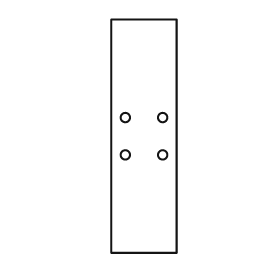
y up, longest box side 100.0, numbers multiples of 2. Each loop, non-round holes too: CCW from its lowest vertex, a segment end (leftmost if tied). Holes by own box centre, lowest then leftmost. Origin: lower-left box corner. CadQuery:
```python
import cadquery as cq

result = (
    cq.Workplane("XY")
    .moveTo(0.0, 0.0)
    .lineTo(28.0, 0.0)
    .lineTo(28.0, 100.0)
    .lineTo(0.0, 100.0)
    .close()
    .moveTo(6.0, 42.0)
    .circle(2.0)
    .moveTo(22.0, 42.0)
    .circle(2.0)
    .moveTo(6.0, 58.0)
    .circle(2.0)
    .moveTo(22.0, 58.0)
    .circle(2.0)
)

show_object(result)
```